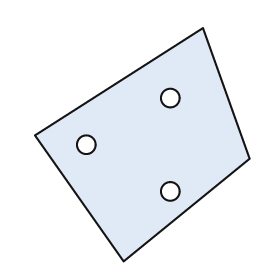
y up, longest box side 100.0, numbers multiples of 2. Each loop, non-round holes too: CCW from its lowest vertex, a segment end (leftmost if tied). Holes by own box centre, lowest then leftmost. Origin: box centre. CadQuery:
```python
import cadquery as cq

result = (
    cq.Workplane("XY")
    .moveTo(-8.0, -50.0)
    .lineTo(46.0, -6.0)
    .lineTo(26.0, 50.0)
    .lineTo(-46.0, 4.0)
    .close()
    .moveTo(12.0, -20.0)
    .circle(4.0)
    .moveTo(-24.0, 0.0)
    .circle(4.0)
    .moveTo(12.0, 20.0)
    .circle(4.0)
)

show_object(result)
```